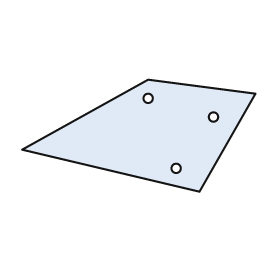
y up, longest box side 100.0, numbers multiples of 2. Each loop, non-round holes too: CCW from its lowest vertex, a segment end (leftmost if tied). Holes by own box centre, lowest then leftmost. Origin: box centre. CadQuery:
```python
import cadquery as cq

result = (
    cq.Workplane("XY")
    .moveTo(26.0, -24.0)
    .lineTo(50.0, 18.0)
    .lineTo(4.0, 24.0)
    .lineTo(-50.0, -6.0)
    .close()
    .moveTo(16.0, -14.0)
    .circle(2.0)
    .moveTo(32.0, 8.0)
    .circle(2.0)
    .moveTo(4.0, 16.0)
    .circle(2.0)
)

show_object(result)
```